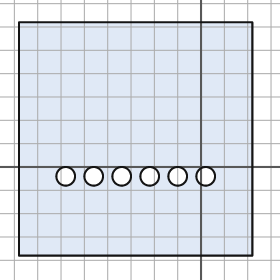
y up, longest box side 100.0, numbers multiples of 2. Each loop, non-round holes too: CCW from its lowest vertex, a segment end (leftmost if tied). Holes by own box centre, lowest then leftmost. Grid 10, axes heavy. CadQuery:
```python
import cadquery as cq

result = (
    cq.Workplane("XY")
    .moveTo(-78.0, -38.0)
    .lineTo(22.0, -38.0)
    .lineTo(22.0, 62.0)
    .lineTo(-78.0, 62.0)
    .close()
    .moveTo(-58.0, -4.0)
    .circle(4.0)
    .moveTo(-46.0, -4.0)
    .circle(4.0)
    .moveTo(-34.0, -4.0)
    .circle(4.0)
    .moveTo(-22.0, -4.0)
    .circle(4.0)
    .moveTo(-10.0, -4.0)
    .circle(4.0)
    .moveTo(2.0, -4.0)
    .circle(4.0)
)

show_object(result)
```